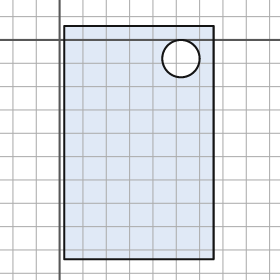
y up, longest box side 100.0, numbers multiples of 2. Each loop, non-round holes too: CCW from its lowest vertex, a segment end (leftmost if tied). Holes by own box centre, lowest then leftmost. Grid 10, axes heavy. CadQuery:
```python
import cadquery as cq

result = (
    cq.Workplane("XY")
    .moveTo(2.0, -94.0)
    .lineTo(66.0, -94.0)
    .lineTo(66.0, 6.0)
    .lineTo(2.0, 6.0)
    .close()
    .moveTo(52.0, -8.0)
    .circle(8.0)
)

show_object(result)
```